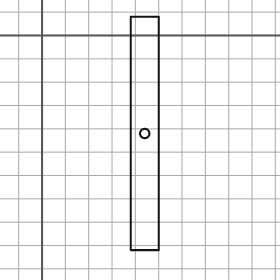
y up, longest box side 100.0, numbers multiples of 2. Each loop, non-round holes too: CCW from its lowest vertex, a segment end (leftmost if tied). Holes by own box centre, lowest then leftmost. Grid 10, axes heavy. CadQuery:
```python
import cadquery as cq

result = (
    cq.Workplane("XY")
    .moveTo(38.0, -92.0)
    .lineTo(50.0, -92.0)
    .lineTo(50.0, 8.0)
    .lineTo(38.0, 8.0)
    .close()
    .moveTo(44.0, -42.0)
    .circle(2.0)
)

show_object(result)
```